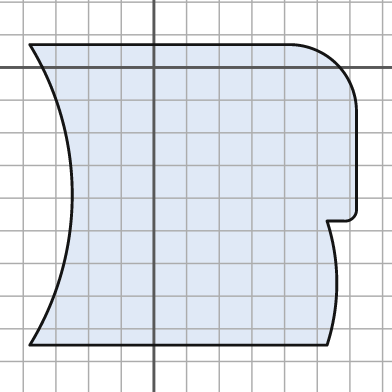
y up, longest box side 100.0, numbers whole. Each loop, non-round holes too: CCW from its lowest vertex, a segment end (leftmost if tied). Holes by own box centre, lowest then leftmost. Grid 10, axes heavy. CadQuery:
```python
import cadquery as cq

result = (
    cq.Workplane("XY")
    .moveTo(-38.0, -85.0)
    .lineTo(53.0, -85.0)
    .threePointArc((56.0, -66.0), (53.0, -47.0))
    .lineTo(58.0, -47.0)
    .threePointArc((61.0, -46.0), (62.0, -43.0))
    .lineTo(62.0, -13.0)
    .threePointArc((56.0, 1.0), (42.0, 7.0))
    .lineTo(-38.0, 7.0)
    .threePointArc((-25.0, -39.0), (-38.0, -85.0))
    .close()
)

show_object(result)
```